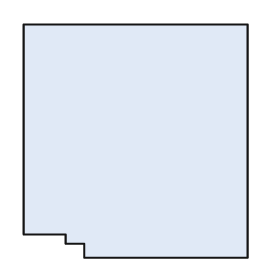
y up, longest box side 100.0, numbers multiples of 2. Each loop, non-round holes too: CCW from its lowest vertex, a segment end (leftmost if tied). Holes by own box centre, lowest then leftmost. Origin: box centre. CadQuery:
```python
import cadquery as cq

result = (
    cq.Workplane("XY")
    .moveTo(-22.0, -50.0)
    .lineTo(48.0, -50.0)
    .lineTo(48.0, 50.0)
    .lineTo(-48.0, 50.0)
    .lineTo(-48.0, -40.0)
    .lineTo(-30.0, -40.0)
    .lineTo(-30.0, -44.0)
    .lineTo(-22.0, -44.0)
    .close()
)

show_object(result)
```